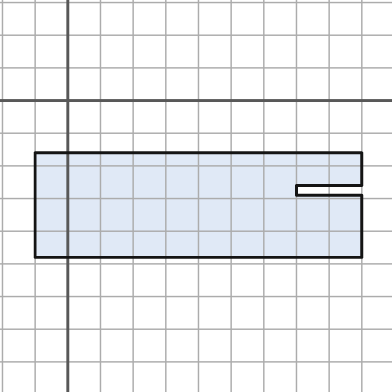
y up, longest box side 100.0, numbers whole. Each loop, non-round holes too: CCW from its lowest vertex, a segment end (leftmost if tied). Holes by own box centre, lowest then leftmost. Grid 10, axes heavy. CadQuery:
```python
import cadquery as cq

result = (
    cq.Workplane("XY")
    .moveTo(-10.0, -48.0)
    .lineTo(90.0, -48.0)
    .lineTo(90.0, -29.0)
    .lineTo(70.0, -29.0)
    .lineTo(70.0, -26.0)
    .lineTo(90.0, -26.0)
    .lineTo(90.0, -16.0)
    .lineTo(-10.0, -16.0)
    .close()
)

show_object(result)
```